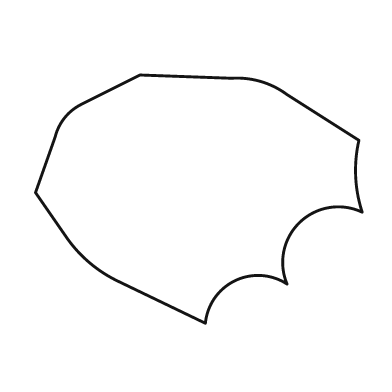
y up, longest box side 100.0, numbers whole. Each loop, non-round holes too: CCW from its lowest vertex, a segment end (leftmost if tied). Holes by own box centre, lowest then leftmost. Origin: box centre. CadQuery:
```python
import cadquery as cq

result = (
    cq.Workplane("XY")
    .moveTo(2.0, -38.0)
    .threePointArc((11.0, -25.0), (27.0, -26.0))
    .threePointArc((31.0, -7.0), (50.0, -4.0))
    .threePointArc((48.0, 7.0), (49.0, 18.0))
    .lineTo(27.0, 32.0)
    .threePointArc((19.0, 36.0), (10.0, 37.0))
    .lineTo(-18.0, 38.0)
    .lineTo(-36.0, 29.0)
    .threePointArc((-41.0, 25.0), (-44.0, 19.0))
    .lineTo(-50.0, 2.0)
    .lineTo(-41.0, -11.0)
    .threePointArc((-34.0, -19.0), (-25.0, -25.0))
    .close()
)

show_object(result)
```